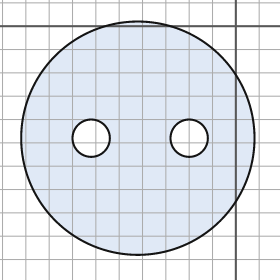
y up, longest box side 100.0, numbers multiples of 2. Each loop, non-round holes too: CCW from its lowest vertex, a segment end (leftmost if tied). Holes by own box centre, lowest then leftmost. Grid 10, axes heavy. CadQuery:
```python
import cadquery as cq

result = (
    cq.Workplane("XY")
    .moveTo(-42.0, -48.0)
    .circle(50.0)
    .moveTo(-62.0, -48.0)
    .circle(8.0)
    .moveTo(-20.0, -48.0)
    .circle(8.0)
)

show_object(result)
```